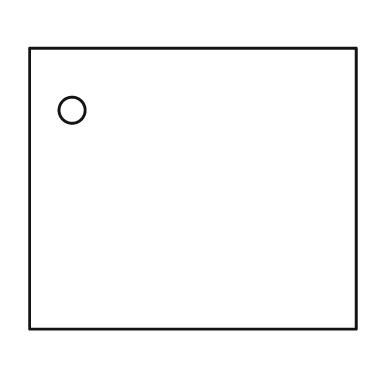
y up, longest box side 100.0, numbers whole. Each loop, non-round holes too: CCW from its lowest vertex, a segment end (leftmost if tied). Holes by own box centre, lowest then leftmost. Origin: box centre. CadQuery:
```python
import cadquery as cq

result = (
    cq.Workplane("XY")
    .moveTo(-50.0, -43.0)
    .lineTo(50.0, -43.0)
    .lineTo(50.0, 43.0)
    .lineTo(-50.0, 43.0)
    .close()
    .moveTo(-37.0, 24.0)
    .circle(4.0)
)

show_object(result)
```